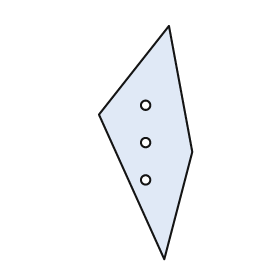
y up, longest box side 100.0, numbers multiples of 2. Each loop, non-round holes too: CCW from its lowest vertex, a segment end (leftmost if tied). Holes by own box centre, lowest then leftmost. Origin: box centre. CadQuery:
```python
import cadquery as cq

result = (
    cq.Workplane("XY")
    .moveTo(8.0, -50.0)
    .lineTo(20.0, -4.0)
    .lineTo(10.0, 50.0)
    .lineTo(-20.0, 12.0)
    .close()
    .moveTo(0.0, -16.0)
    .circle(2.0)
    .moveTo(0.0, 0.0)
    .circle(2.0)
    .moveTo(0.0, 16.0)
    .circle(2.0)
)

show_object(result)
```